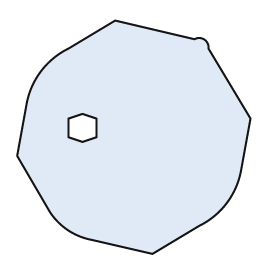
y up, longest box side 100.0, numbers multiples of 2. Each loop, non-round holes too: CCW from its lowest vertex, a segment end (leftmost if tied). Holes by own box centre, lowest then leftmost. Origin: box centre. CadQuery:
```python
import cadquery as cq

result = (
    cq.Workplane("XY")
    .moveTo(8.0, -50.0)
    .lineTo(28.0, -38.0)
    .threePointArc((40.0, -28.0), (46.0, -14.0))
    .lineTo(50.0, 8.0)
    .lineTo(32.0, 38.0)
    .threePointArc((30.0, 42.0), (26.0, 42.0))
    .lineTo(-8.0, 50.0)
    .lineTo(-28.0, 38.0)
    .threePointArc((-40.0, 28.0), (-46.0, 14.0))
    .lineTo(-50.0, -8.0)
    .lineTo(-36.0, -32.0)
    .threePointArc((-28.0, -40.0), (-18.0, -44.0))
    .close()
    .moveTo(-22.0, -2.0)
    .lineTo(-16.0, 0.0)
    .lineTo(-16.0, 8.0)
    .lineTo(-22.0, 10.0)
    .lineTo(-28.0, 8.0)
    .lineTo(-28.0, 0.0)
    .close()
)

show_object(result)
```